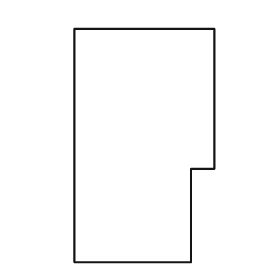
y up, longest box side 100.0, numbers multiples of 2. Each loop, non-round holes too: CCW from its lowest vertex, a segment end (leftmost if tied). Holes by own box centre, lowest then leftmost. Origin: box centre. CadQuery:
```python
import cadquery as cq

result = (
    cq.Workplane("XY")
    .moveTo(-30.0, -50.0)
    .lineTo(20.0, -50.0)
    .lineTo(20.0, -10.0)
    .lineTo(30.0, -10.0)
    .lineTo(30.0, 50.0)
    .lineTo(-30.0, 50.0)
    .close()
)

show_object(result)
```